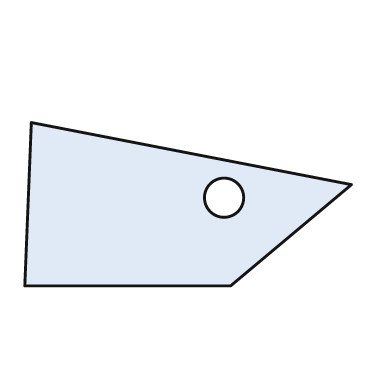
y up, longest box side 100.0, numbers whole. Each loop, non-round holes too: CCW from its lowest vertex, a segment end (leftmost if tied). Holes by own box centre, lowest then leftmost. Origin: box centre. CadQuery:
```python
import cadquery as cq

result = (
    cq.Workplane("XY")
    .moveTo(-50.0, -25.0)
    .lineTo(13.0, -25.0)
    .lineTo(50.0, 6.0)
    .lineTo(-48.0, 25.0)
    .close()
    .moveTo(11.0, 2.0)
    .circle(6.0)
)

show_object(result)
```